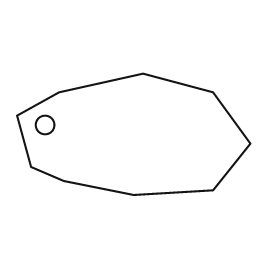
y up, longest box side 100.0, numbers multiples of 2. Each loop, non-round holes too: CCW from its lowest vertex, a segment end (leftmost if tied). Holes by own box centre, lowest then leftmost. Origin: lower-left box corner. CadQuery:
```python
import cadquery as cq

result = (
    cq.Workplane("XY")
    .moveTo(50.0, 0.0)
    .lineTo(84.0, 2.0)
    .lineTo(100.0, 22.0)
    .lineTo(84.0, 44.0)
    .lineTo(54.0, 52.0)
    .lineTo(18.0, 44.0)
    .lineTo(0.0, 34.0)
    .lineTo(6.0, 12.0)
    .lineTo(20.0, 6.0)
    .close()
    .moveTo(12.0, 30.0)
    .circle(4.0)
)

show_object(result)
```